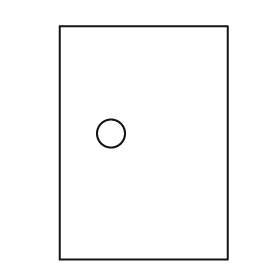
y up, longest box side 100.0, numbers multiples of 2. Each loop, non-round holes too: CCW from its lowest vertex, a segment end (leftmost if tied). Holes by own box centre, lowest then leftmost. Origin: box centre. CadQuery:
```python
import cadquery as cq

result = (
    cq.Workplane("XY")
    .moveTo(-36.0, -50.0)
    .lineTo(36.0, -50.0)
    .lineTo(36.0, 50.0)
    .lineTo(-36.0, 50.0)
    .close()
    .moveTo(-14.0, 4.0)
    .circle(6.0)
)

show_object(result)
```